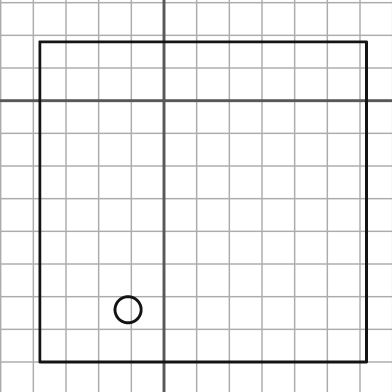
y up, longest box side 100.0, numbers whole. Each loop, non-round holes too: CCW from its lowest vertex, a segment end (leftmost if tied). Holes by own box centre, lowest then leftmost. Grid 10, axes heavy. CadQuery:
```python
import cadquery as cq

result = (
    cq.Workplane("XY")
    .moveTo(-38.0, -80.0)
    .lineTo(62.0, -80.0)
    .lineTo(62.0, 18.0)
    .lineTo(-38.0, 18.0)
    .close()
    .moveTo(-11.0, -64.0)
    .circle(4.0)
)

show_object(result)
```